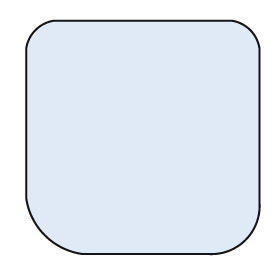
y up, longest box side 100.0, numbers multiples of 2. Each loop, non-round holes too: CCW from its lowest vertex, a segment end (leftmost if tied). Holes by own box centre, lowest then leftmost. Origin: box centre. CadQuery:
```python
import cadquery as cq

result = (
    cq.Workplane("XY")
    .moveTo(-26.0, -50.0)
    .lineTo(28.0, -50.0)
    .threePointArc((44.0, -44.0), (50.0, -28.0))
    .lineTo(50.0, 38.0)
    .threePointArc((46.0, 46.0), (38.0, 50.0))
    .lineTo(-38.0, 50.0)
    .threePointArc((-46.0, 46.0), (-50.0, 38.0))
    .lineTo(-50.0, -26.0)
    .threePointArc((-42.0, -42.0), (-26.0, -50.0))
    .close()
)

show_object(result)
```